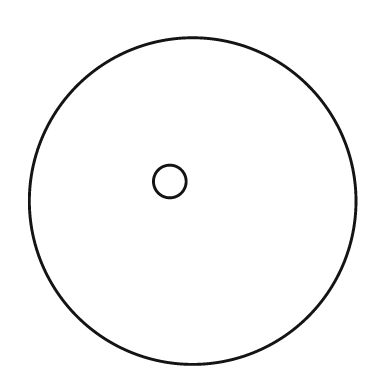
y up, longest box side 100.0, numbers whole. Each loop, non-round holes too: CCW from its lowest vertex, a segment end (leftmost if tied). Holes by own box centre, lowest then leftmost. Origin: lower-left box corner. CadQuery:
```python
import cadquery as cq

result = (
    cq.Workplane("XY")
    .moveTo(50.0, 50.0)
    .circle(50.0)
    .moveTo(43.0, 56.0)
    .circle(5.0)
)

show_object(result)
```